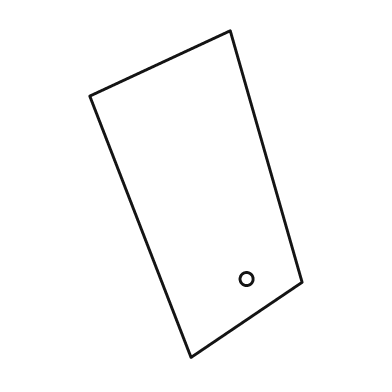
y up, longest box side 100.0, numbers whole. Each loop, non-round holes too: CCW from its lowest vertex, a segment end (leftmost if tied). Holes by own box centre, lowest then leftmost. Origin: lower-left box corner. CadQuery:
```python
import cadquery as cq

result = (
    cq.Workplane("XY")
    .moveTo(31.0, 0.0)
    .lineTo(65.0, 23.0)
    .lineTo(43.0, 100.0)
    .lineTo(0.0, 80.0)
    .close()
    .moveTo(48.0, 24.0)
    .circle(2.0)
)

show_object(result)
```